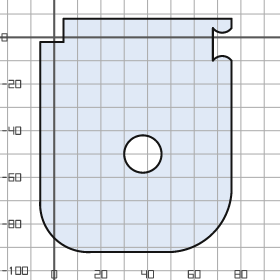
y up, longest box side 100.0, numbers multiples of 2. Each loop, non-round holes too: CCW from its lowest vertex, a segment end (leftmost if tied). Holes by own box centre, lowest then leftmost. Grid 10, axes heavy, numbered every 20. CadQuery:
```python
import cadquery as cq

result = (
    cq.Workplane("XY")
    .moveTo(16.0, -92.0)
    .lineTo(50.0, -92.0)
    .threePointArc((68.0, -84.0), (76.0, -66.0))
    .lineTo(76.0, -10.0)
    .threePointArc((72.0, -8.0), (68.0, -10.0))
    .lineTo(68.0, 4.0)
    .threePointArc((72.0, 2.0), (76.0, 4.0))
    .lineTo(76.0, 8.0)
    .lineTo(4.0, 8.0)
    .lineTo(4.0, -2.0)
    .lineTo(-6.0, -2.0)
    .lineTo(-6.0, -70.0)
    .threePointArc((0.0, -86.0), (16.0, -92.0))
    .close()
    .moveTo(38.0, -50.0)
    .circle(8.0)
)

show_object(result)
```